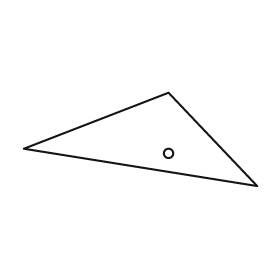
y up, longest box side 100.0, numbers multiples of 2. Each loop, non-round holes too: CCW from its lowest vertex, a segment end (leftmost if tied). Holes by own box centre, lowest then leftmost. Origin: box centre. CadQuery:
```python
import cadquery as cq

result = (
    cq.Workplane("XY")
    .moveTo(50.0, -20.0)
    .lineTo(12.0, 20.0)
    .lineTo(-50.0, -4.0)
    .close()
    .moveTo(12.0, -6.0)
    .circle(2.0)
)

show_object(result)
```